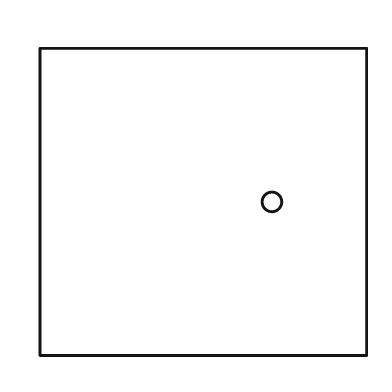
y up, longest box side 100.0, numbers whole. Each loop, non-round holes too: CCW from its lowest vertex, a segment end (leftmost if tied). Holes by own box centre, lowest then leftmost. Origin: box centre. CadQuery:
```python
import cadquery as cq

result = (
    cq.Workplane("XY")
    .moveTo(-50.0, -47.0)
    .lineTo(50.0, -47.0)
    .lineTo(50.0, 47.0)
    .lineTo(-50.0, 47.0)
    .close()
    .moveTo(21.0, 0.0)
    .circle(3.0)
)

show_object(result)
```